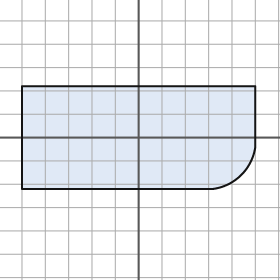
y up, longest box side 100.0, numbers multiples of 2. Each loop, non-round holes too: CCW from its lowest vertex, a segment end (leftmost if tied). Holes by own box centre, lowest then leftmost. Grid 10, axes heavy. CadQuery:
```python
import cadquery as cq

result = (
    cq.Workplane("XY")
    .moveTo(-50.0, -22.0)
    .lineTo(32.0, -22.0)
    .threePointArc((44.0, -16.0), (50.0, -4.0))
    .lineTo(50.0, 22.0)
    .lineTo(-50.0, 22.0)
    .close()
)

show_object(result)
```